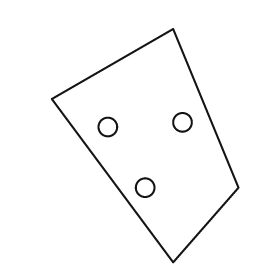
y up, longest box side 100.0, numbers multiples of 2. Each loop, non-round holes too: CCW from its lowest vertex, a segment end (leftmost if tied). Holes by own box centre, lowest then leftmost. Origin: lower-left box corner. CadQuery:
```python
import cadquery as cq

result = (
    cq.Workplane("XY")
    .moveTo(52.0, 0.0)
    .lineTo(80.0, 32.0)
    .lineTo(52.0, 100.0)
    .lineTo(0.0, 70.0)
    .close()
    .moveTo(40.0, 32.0)
    .circle(4.0)
    .moveTo(24.0, 58.0)
    .circle(4.0)
    .moveTo(56.0, 60.0)
    .circle(4.0)
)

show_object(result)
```